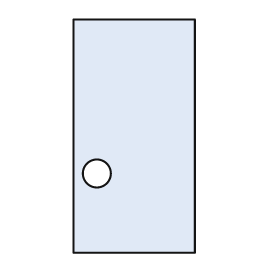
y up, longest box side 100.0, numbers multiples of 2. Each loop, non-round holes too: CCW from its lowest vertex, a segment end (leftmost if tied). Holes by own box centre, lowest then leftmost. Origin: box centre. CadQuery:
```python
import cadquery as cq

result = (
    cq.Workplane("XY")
    .moveTo(-26.0, -50.0)
    .lineTo(26.0, -50.0)
    .lineTo(26.0, 50.0)
    .lineTo(-26.0, 50.0)
    .close()
    .moveTo(-16.0, -16.0)
    .circle(6.0)
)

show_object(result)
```